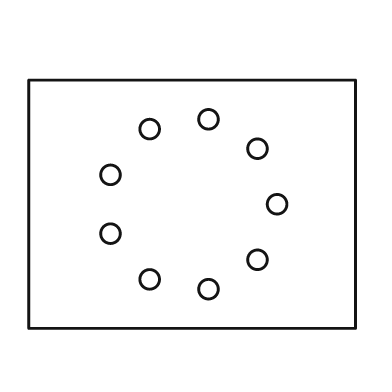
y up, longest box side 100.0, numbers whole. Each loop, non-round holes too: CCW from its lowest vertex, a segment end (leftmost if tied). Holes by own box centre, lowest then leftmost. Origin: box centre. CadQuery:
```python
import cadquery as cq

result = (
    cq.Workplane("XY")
    .moveTo(-50.0, -38.0)
    .lineTo(50.0, -38.0)
    .lineTo(50.0, 38.0)
    .lineTo(-50.0, 38.0)
    .close()
    .moveTo(5.0, -26.0)
    .circle(3.0)
    .moveTo(-13.0, -23.0)
    .circle(3.0)
    .moveTo(20.0, -17.0)
    .circle(3.0)
    .moveTo(-25.0, -9.0)
    .circle(3.0)
    .moveTo(26.0, 0.0)
    .circle(3.0)
    .moveTo(-25.0, 9.0)
    .circle(3.0)
    .moveTo(20.0, 17.0)
    .circle(3.0)
    .moveTo(-13.0, 23.0)
    .circle(3.0)
    .moveTo(5.0, 26.0)
    .circle(3.0)
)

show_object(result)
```